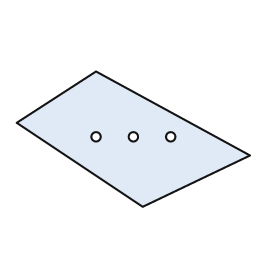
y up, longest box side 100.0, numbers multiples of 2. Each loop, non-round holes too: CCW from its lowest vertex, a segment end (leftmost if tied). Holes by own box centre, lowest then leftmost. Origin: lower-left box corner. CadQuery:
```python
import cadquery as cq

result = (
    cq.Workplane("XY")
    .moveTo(54.0, 0.0)
    .lineTo(100.0, 22.0)
    .lineTo(34.0, 58.0)
    .lineTo(0.0, 36.0)
    .close()
    .moveTo(34.0, 30.0)
    .circle(2.0)
    .moveTo(50.0, 30.0)
    .circle(2.0)
    .moveTo(66.0, 30.0)
    .circle(2.0)
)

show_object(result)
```